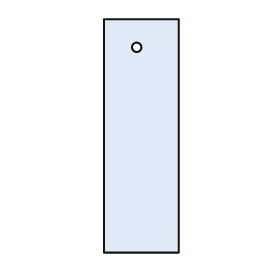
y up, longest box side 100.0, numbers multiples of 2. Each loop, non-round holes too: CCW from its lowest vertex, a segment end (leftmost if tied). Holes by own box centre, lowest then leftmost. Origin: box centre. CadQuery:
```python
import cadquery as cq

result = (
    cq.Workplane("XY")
    .moveTo(-16.0, -50.0)
    .lineTo(16.0, -50.0)
    .lineTo(16.0, 50.0)
    .lineTo(-16.0, 50.0)
    .close()
    .moveTo(-2.0, 38.0)
    .circle(2.0)
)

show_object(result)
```